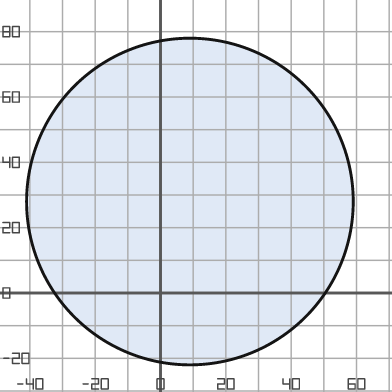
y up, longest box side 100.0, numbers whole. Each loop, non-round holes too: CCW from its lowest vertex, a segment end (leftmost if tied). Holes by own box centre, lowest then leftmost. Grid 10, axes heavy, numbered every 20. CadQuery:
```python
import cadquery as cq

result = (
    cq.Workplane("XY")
    .moveTo(9.0, 28.0)
    .circle(50.0)
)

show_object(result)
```